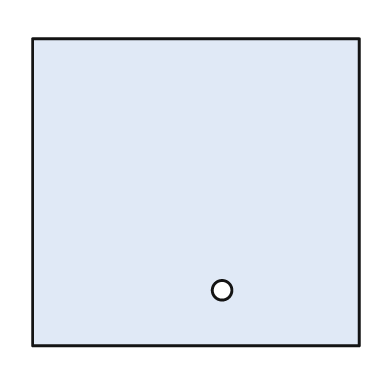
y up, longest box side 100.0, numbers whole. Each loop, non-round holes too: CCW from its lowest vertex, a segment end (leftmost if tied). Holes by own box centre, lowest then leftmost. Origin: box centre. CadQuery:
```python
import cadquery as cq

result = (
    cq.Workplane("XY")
    .moveTo(-50.0, -47.0)
    .lineTo(50.0, -47.0)
    .lineTo(50.0, 47.0)
    .lineTo(-50.0, 47.0)
    .close()
    .moveTo(8.0, -30.0)
    .circle(3.0)
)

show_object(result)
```